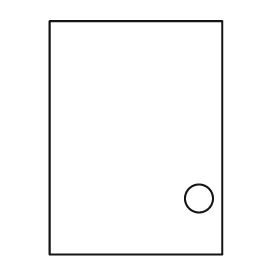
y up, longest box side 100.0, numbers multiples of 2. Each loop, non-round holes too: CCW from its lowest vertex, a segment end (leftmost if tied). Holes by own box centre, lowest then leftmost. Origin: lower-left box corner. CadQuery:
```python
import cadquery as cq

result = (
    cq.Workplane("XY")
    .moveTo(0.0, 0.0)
    .lineTo(74.0, 0.0)
    .lineTo(74.0, 100.0)
    .lineTo(0.0, 100.0)
    .close()
    .moveTo(64.0, 24.0)
    .circle(6.0)
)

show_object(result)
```